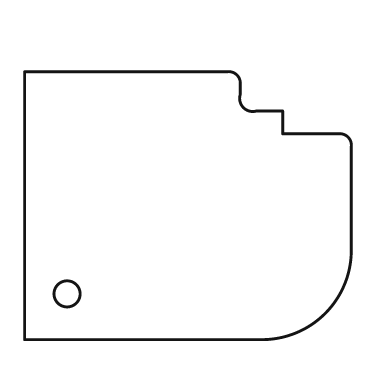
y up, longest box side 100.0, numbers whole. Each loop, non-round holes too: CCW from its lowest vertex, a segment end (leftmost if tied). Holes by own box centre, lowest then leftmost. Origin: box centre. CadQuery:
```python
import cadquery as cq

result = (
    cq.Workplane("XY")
    .moveTo(-50.0, -41.0)
    .lineTo(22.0, -41.0)
    .threePointArc((42.0, -33.0), (50.0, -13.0))
    .lineTo(50.0, 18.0)
    .threePointArc((49.0, 21.0), (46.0, 22.0))
    .lineTo(29.0, 22.0)
    .lineTo(29.0, 29.0)
    .lineTo(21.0, 29.0)
    .threePointArc((17.0, 30.0), (16.0, 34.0))
    .lineTo(16.0, 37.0)
    .threePointArc((15.0, 40.0), (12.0, 41.0))
    .lineTo(-50.0, 41.0)
    .close()
    .moveTo(-37.0, -27.0)
    .circle(4.0)
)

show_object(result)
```